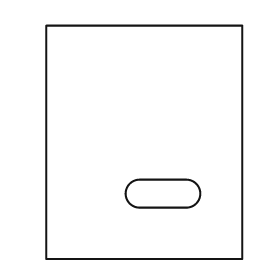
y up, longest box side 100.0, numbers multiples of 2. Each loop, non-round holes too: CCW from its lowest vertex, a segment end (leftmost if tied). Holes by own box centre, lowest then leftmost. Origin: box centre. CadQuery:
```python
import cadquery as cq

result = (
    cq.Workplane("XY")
    .moveTo(-42.0, -50.0)
    .lineTo(42.0, -50.0)
    .lineTo(42.0, 50.0)
    .lineTo(-42.0, 50.0)
    .close()
    .moveTo(-2.0, -28.0)
    .lineTo(18.0, -28.0)
    .threePointArc((24.0, -22.0), (18.0, -16.0))
    .lineTo(-2.0, -16.0)
    .threePointArc((-8.0, -22.0), (-2.0, -28.0))
    .close()
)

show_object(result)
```